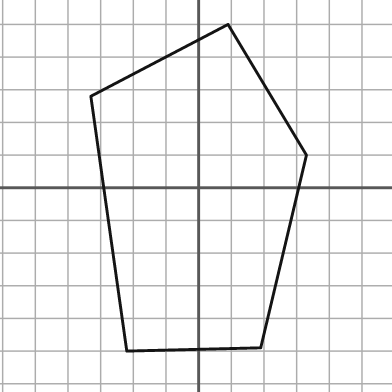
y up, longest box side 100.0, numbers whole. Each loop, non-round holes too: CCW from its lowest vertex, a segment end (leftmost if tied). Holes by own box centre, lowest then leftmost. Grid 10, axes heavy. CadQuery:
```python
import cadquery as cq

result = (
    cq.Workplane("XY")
    .moveTo(-22.0, -50.0)
    .lineTo(19.0, -49.0)
    .lineTo(33.0, 10.0)
    .lineTo(9.0, 50.0)
    .lineTo(-33.0, 28.0)
    .close()
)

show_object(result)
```